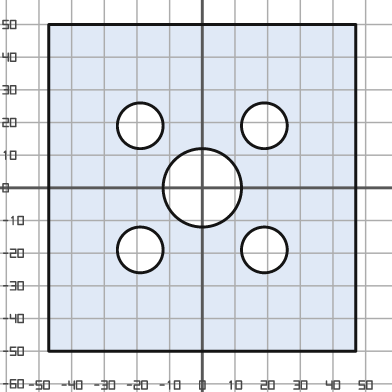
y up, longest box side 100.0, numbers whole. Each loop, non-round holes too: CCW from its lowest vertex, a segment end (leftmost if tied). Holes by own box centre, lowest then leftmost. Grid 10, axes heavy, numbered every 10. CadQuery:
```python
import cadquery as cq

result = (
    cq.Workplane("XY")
    .moveTo(-47.0, -50.0)
    .lineTo(47.0, -50.0)
    .lineTo(47.0, 50.0)
    .lineTo(-47.0, 50.0)
    .close()
    .moveTo(-19.0, -19.0)
    .circle(7.0)
    .moveTo(19.0, -19.0)
    .circle(7.0)
    .moveTo(0.0, 0.0)
    .circle(12.0)
    .moveTo(-19.0, 19.0)
    .circle(7.0)
    .moveTo(19.0, 19.0)
    .circle(7.0)
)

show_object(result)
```